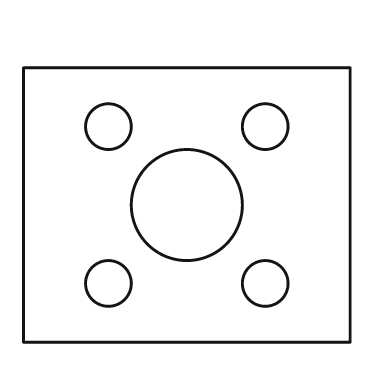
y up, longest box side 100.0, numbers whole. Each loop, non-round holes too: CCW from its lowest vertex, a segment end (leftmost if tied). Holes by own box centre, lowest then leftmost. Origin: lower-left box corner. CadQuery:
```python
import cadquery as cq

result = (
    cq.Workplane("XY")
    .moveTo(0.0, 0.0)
    .lineTo(100.0, 0.0)
    .lineTo(100.0, 84.0)
    .lineTo(0.0, 84.0)
    .close()
    .moveTo(26.0, 18.0)
    .circle(7.0)
    .moveTo(74.0, 18.0)
    .circle(7.0)
    .moveTo(50.0, 42.0)
    .circle(17.0)
    .moveTo(26.0, 66.0)
    .circle(7.0)
    .moveTo(74.0, 66.0)
    .circle(7.0)
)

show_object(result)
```